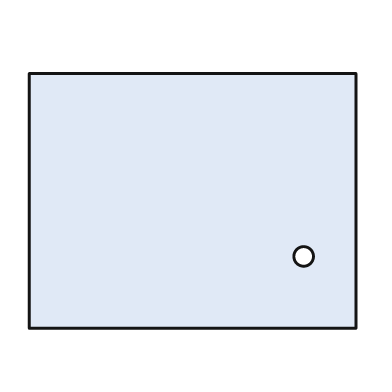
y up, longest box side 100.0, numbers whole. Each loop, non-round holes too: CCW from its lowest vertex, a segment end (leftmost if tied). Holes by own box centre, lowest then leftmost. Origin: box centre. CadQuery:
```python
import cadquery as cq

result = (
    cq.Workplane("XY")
    .moveTo(-50.0, -39.0)
    .lineTo(50.0, -39.0)
    .lineTo(50.0, 39.0)
    .lineTo(-50.0, 39.0)
    .close()
    .moveTo(34.0, -17.0)
    .circle(3.0)
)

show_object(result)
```